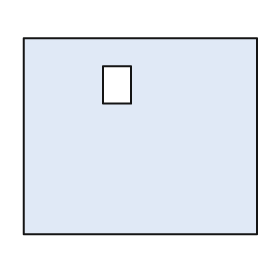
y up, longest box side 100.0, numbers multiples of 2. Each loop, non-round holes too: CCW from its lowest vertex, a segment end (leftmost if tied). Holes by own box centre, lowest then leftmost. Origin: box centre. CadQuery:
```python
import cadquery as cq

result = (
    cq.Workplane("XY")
    .moveTo(-50.0, -42.0)
    .lineTo(50.0, -42.0)
    .lineTo(50.0, 42.0)
    .lineTo(-50.0, 42.0)
    .close()
    .moveTo(-16.0, 14.0)
    .lineTo(-4.0, 14.0)
    .lineTo(-4.0, 30.0)
    .lineTo(-16.0, 30.0)
    .close()
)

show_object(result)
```